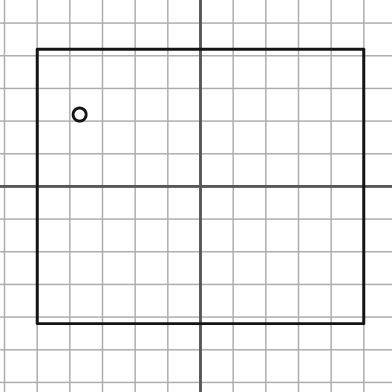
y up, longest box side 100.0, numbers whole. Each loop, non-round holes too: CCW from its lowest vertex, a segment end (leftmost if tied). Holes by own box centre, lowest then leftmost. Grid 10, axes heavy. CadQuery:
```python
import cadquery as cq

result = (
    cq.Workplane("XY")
    .moveTo(-50.0, -42.0)
    .lineTo(50.0, -42.0)
    .lineTo(50.0, 42.0)
    .lineTo(-50.0, 42.0)
    .close()
    .moveTo(-37.0, 22.0)
    .circle(2.0)
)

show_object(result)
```